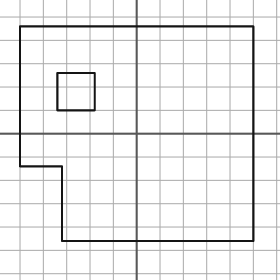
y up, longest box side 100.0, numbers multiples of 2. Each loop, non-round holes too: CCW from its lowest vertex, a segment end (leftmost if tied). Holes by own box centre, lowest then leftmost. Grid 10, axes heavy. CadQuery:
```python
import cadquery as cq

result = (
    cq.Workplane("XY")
    .moveTo(-32.0, -46.0)
    .lineTo(50.0, -46.0)
    .lineTo(50.0, 46.0)
    .lineTo(-50.0, 46.0)
    .lineTo(-50.0, -14.0)
    .lineTo(-32.0, -14.0)
    .close()
    .moveTo(-34.0, 10.0)
    .lineTo(-18.0, 10.0)
    .lineTo(-18.0, 26.0)
    .lineTo(-34.0, 26.0)
    .close()
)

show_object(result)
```